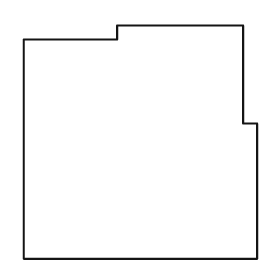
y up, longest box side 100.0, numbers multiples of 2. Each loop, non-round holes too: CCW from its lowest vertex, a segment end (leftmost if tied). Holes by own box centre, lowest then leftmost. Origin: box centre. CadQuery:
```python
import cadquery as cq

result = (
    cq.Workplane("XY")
    .moveTo(-50.0, -50.0)
    .lineTo(50.0, -50.0)
    .lineTo(50.0, 8.0)
    .lineTo(44.0, 8.0)
    .lineTo(44.0, 50.0)
    .lineTo(-10.0, 50.0)
    .lineTo(-10.0, 44.0)
    .lineTo(-50.0, 44.0)
    .close()
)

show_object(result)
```